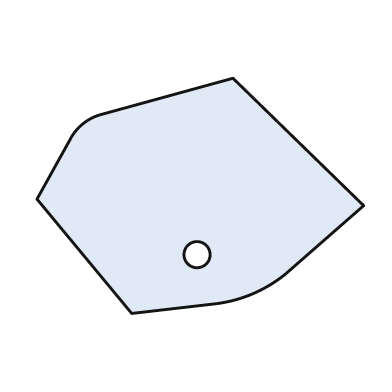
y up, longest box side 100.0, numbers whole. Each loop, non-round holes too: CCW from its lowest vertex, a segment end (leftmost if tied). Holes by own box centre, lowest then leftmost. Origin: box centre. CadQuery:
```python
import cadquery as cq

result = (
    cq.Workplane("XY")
    .moveTo(-21.0, -36.0)
    .lineTo(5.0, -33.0)
    .threePointArc((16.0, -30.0), (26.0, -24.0))
    .lineTo(50.0, -3.0)
    .lineTo(10.0, 36.0)
    .lineTo(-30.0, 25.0)
    .threePointArc((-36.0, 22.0), (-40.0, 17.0))
    .lineTo(-50.0, -1.0)
    .close()
    .moveTo(-1.0, -18.0)
    .circle(4.0)
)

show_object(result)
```